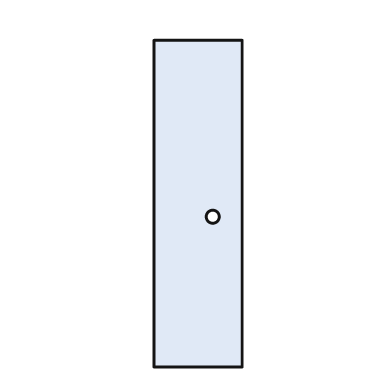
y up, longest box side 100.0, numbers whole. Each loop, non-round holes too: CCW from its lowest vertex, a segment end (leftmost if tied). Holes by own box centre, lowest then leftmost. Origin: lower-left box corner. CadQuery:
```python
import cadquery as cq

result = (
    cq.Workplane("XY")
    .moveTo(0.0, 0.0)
    .lineTo(27.0, 0.0)
    .lineTo(27.0, 100.0)
    .lineTo(0.0, 100.0)
    .close()
    .moveTo(18.0, 46.0)
    .circle(2.0)
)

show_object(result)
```